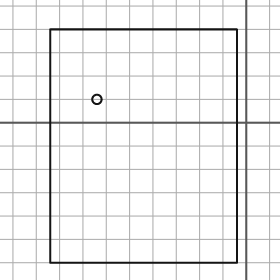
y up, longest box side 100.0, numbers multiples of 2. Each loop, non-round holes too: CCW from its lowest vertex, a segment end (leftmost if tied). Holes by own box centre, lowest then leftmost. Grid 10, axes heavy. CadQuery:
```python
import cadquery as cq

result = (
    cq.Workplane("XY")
    .moveTo(-84.0, -60.0)
    .lineTo(-4.0, -60.0)
    .lineTo(-4.0, 40.0)
    .lineTo(-84.0, 40.0)
    .close()
    .moveTo(-64.0, 10.0)
    .circle(2.0)
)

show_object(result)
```